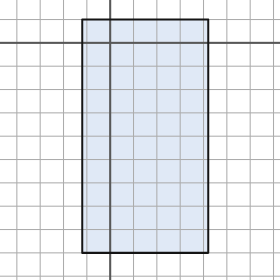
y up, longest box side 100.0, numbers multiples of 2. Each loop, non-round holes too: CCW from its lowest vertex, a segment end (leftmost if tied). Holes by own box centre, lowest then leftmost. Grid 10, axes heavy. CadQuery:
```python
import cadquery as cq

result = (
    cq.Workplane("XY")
    .moveTo(-12.0, -90.0)
    .lineTo(42.0, -90.0)
    .lineTo(42.0, 10.0)
    .lineTo(-12.0, 10.0)
    .close()
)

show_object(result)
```